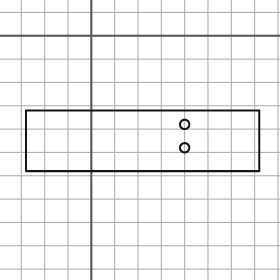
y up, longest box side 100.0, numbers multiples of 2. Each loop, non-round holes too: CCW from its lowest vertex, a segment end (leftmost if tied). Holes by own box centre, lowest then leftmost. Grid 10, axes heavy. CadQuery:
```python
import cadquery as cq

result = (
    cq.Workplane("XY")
    .moveTo(-28.0, -58.0)
    .lineTo(72.0, -58.0)
    .lineTo(72.0, -32.0)
    .lineTo(-28.0, -32.0)
    .close()
    .moveTo(40.0, -48.0)
    .circle(2.0)
    .moveTo(40.0, -38.0)
    .circle(2.0)
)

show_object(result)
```